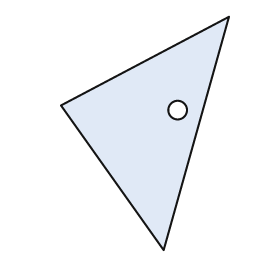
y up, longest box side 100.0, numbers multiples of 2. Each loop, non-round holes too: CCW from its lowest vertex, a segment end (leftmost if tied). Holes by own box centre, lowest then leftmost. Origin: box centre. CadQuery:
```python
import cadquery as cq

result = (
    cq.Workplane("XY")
    .moveTo(8.0, -50.0)
    .lineTo(36.0, 50.0)
    .lineTo(-36.0, 12.0)
    .close()
    .moveTo(14.0, 10.0)
    .circle(4.0)
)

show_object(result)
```